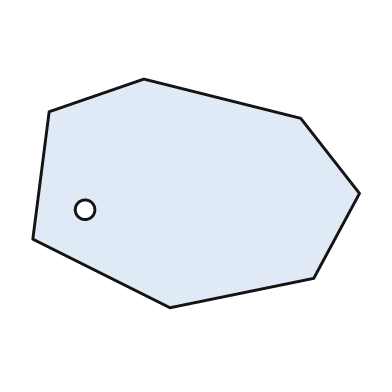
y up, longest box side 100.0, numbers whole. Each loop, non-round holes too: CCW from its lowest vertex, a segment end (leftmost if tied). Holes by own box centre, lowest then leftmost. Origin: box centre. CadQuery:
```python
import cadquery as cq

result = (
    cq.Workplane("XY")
    .moveTo(-8.0, -35.0)
    .lineTo(36.0, -26.0)
    .lineTo(50.0, 0.0)
    .lineTo(32.0, 23.0)
    .lineTo(-16.0, 35.0)
    .lineTo(-45.0, 25.0)
    .lineTo(-50.0, -14.0)
    .close()
    .moveTo(-34.0, -5.0)
    .circle(3.0)
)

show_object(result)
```